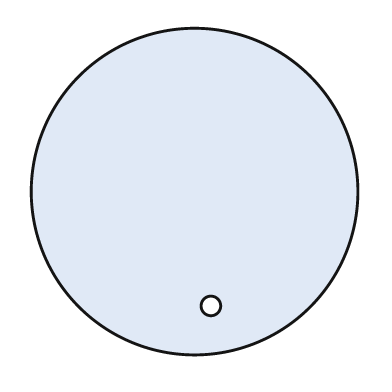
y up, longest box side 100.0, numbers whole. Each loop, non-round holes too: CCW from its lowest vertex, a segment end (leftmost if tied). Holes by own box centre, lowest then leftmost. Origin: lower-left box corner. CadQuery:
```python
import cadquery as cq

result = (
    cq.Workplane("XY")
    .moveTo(50.0, 50.0)
    .circle(50.0)
    .moveTo(55.0, 15.0)
    .circle(3.0)
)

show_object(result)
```